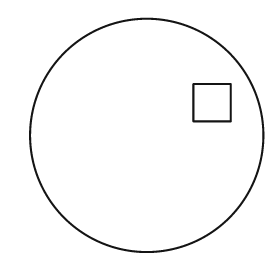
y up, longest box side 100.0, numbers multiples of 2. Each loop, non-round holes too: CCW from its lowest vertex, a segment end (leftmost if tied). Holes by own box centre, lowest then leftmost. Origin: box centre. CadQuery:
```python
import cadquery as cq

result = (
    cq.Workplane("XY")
    .moveTo(0.0, 0.0)
    .circle(50.0)
    .moveTo(20.0, 6.0)
    .lineTo(36.0, 6.0)
    .lineTo(36.0, 22.0)
    .lineTo(20.0, 22.0)
    .close()
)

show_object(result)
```